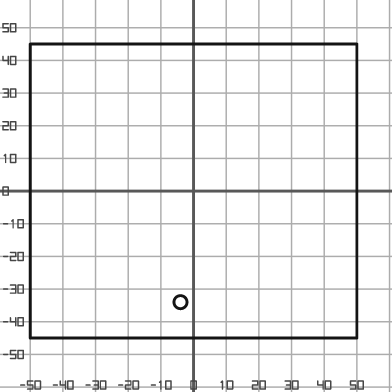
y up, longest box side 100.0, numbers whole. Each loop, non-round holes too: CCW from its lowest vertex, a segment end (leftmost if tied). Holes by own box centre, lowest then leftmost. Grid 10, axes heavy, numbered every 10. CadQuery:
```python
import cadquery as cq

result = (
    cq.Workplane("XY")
    .moveTo(-50.0, -45.0)
    .lineTo(50.0, -45.0)
    .lineTo(50.0, 45.0)
    .lineTo(-50.0, 45.0)
    .close()
    .moveTo(-4.0, -34.0)
    .circle(2.0)
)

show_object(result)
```